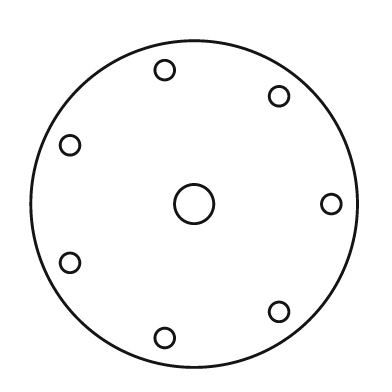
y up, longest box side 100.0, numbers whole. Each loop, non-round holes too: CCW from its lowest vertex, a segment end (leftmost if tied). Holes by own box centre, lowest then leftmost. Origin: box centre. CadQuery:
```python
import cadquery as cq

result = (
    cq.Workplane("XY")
    .moveTo(0.0, 0.0)
    .circle(50.0)
    .moveTo(-9.0, -41.0)
    .circle(3.0)
    .moveTo(26.0, -33.0)
    .circle(3.0)
    .moveTo(-38.0, -18.0)
    .circle(3.0)
    .moveTo(0.0, 0.0)
    .circle(6.0)
    .moveTo(42.0, 0.0)
    .circle(3.0)
    .moveTo(-38.0, 18.0)
    .circle(3.0)
    .moveTo(26.0, 33.0)
    .circle(3.0)
    .moveTo(-9.0, 41.0)
    .circle(3.0)
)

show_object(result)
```